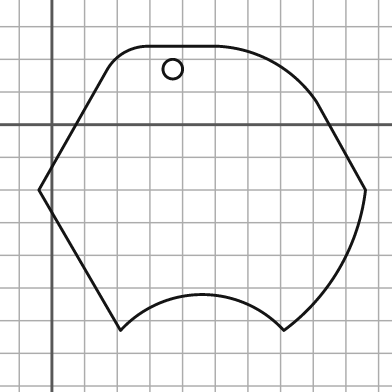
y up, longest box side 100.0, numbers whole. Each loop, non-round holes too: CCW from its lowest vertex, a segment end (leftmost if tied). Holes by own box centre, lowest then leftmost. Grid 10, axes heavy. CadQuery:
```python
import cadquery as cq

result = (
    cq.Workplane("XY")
    .moveTo(21.0, -63.0)
    .threePointArc((46.0, -52.0), (71.0, -63.0))
    .threePointArc((88.0, -44.0), (96.0, -20.0))
    .lineTo(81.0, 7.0)
    .threePointArc((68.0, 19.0), (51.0, 24.0))
    .lineTo(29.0, 24.0)
    .threePointArc((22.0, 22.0), (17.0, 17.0))
    .lineTo(-4.0, -20.0)
    .close()
    .moveTo(37.0, 17.0)
    .circle(3.0)
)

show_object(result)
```